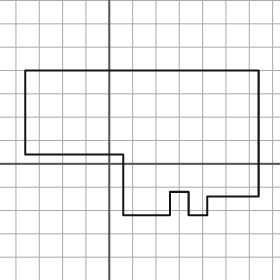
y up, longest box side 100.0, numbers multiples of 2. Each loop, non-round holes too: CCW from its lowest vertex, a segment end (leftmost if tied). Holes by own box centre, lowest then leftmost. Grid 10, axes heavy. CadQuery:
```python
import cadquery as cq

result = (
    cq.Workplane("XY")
    .moveTo(6.0, -22.0)
    .lineTo(26.0, -22.0)
    .lineTo(26.0, -12.0)
    .lineTo(34.0, -12.0)
    .lineTo(34.0, -22.0)
    .lineTo(42.0, -22.0)
    .lineTo(42.0, -14.0)
    .lineTo(64.0, -14.0)
    .lineTo(64.0, 40.0)
    .lineTo(-36.0, 40.0)
    .lineTo(-36.0, 4.0)
    .lineTo(6.0, 4.0)
    .close()
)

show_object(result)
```